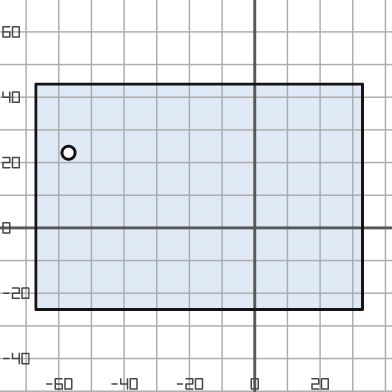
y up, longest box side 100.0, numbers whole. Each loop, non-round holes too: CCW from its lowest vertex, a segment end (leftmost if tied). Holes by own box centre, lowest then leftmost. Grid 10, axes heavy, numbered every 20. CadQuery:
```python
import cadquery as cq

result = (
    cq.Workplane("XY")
    .moveTo(-67.0, -25.0)
    .lineTo(33.0, -25.0)
    .lineTo(33.0, 44.0)
    .lineTo(-67.0, 44.0)
    .close()
    .moveTo(-57.0, 23.0)
    .circle(2.0)
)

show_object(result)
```